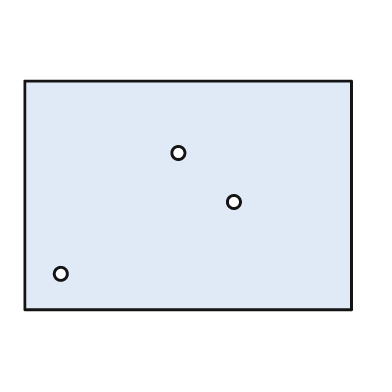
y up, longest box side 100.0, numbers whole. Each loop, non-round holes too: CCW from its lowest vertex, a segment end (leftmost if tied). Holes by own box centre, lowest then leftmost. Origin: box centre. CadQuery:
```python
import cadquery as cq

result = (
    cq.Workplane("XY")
    .moveTo(-50.0, -35.0)
    .lineTo(50.0, -35.0)
    .lineTo(50.0, 35.0)
    .lineTo(-50.0, 35.0)
    .close()
    .moveTo(-39.0, -24.0)
    .circle(2.0)
    .moveTo(14.0, -2.0)
    .circle(2.0)
    .moveTo(-3.0, 13.0)
    .circle(2.0)
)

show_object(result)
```